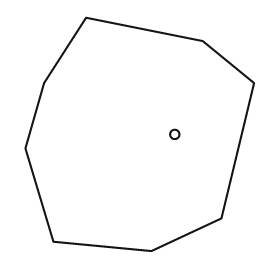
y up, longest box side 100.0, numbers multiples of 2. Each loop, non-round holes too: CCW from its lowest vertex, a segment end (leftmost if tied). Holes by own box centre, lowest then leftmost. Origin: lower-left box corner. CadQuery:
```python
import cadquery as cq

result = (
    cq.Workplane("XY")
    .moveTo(54.0, 0.0)
    .lineTo(84.0, 14.0)
    .lineTo(98.0, 72.0)
    .lineTo(76.0, 90.0)
    .lineTo(26.0, 100.0)
    .lineTo(8.0, 72.0)
    .lineTo(0.0, 44.0)
    .lineTo(12.0, 4.0)
    .close()
    .moveTo(64.0, 50.0)
    .circle(2.0)
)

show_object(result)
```